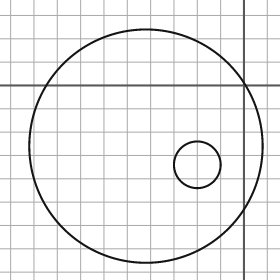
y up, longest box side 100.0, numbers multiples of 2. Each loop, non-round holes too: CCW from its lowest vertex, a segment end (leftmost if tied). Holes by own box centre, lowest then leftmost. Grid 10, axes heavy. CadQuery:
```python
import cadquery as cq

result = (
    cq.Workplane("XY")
    .moveTo(-42.0, -26.0)
    .circle(50.0)
    .moveTo(-20.0, -34.0)
    .circle(10.0)
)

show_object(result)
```